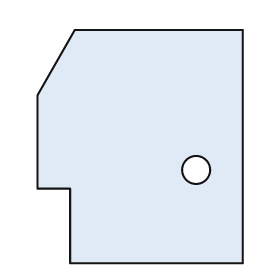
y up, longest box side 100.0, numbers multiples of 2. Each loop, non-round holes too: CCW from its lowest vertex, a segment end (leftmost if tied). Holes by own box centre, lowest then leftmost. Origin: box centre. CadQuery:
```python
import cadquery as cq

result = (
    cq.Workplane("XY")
    .moveTo(-30.0, -50.0)
    .lineTo(44.0, -50.0)
    .lineTo(44.0, 50.0)
    .lineTo(-28.0, 50.0)
    .lineTo(-44.0, 22.0)
    .lineTo(-44.0, -18.0)
    .lineTo(-30.0, -18.0)
    .close()
    .moveTo(24.0, -10.0)
    .circle(6.0)
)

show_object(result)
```